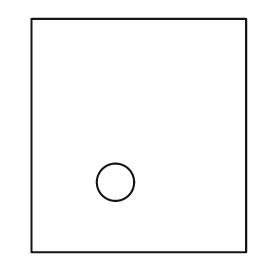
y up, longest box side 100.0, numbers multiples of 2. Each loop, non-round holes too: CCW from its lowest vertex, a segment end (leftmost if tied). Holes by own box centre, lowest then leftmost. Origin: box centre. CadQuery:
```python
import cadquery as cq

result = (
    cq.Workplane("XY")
    .moveTo(-46.0, -50.0)
    .lineTo(46.0, -50.0)
    .lineTo(46.0, 50.0)
    .lineTo(-46.0, 50.0)
    .close()
    .moveTo(-10.0, -20.0)
    .circle(8.0)
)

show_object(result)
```